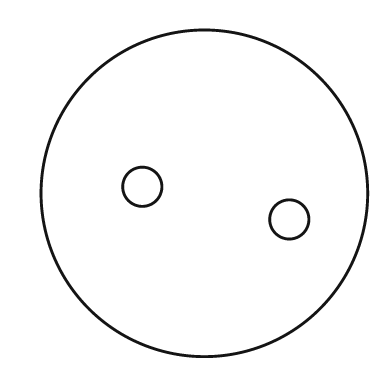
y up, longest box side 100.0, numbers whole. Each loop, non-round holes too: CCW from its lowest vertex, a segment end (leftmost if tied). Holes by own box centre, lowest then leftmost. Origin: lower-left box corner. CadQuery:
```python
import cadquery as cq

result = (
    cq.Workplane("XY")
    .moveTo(50.0, 50.0)
    .circle(50.0)
    .moveTo(76.0, 42.0)
    .circle(6.0)
    .moveTo(31.0, 52.0)
    .circle(6.0)
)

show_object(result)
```